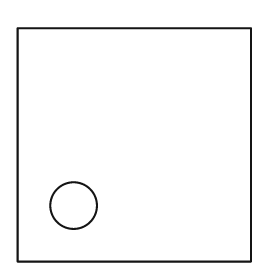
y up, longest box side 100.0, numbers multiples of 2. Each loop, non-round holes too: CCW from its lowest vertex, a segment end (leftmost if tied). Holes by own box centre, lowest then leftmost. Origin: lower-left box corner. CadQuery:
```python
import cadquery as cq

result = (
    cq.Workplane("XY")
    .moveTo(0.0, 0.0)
    .lineTo(100.0, 0.0)
    .lineTo(100.0, 100.0)
    .lineTo(0.0, 100.0)
    .close()
    .moveTo(24.0, 24.0)
    .circle(10.0)
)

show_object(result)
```